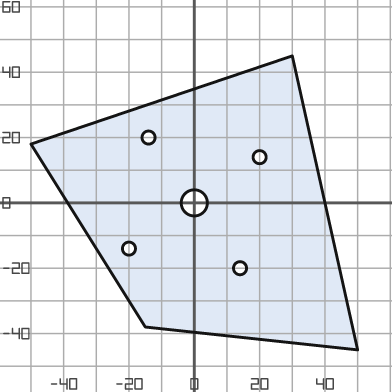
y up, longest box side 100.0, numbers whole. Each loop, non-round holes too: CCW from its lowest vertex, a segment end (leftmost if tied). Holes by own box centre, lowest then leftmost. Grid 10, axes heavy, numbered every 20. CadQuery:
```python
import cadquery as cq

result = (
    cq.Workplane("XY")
    .moveTo(50.0, -45.0)
    .lineTo(30.0, 45.0)
    .lineTo(-50.0, 18.0)
    .lineTo(-15.0, -38.0)
    .close()
    .moveTo(14.0, -20.0)
    .circle(2.0)
    .moveTo(-20.0, -14.0)
    .circle(2.0)
    .moveTo(0.0, 0.0)
    .circle(4.0)
    .moveTo(20.0, 14.0)
    .circle(2.0)
    .moveTo(-14.0, 20.0)
    .circle(2.0)
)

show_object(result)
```